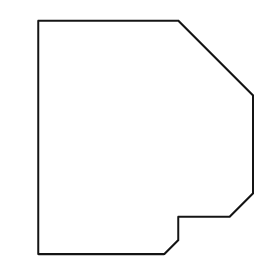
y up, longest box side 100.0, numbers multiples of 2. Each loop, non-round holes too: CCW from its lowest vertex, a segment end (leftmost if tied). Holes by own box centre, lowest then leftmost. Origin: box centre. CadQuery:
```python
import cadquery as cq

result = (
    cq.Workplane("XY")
    .moveTo(-46.0, -50.0)
    .lineTo(8.0, -50.0)
    .lineTo(14.0, -44.0)
    .lineTo(14.0, -34.0)
    .lineTo(36.0, -34.0)
    .lineTo(46.0, -24.0)
    .lineTo(46.0, 18.0)
    .lineTo(14.0, 50.0)
    .lineTo(-46.0, 50.0)
    .close()
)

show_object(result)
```